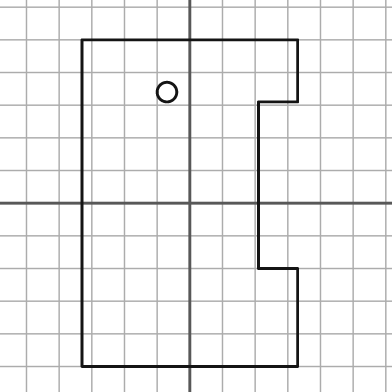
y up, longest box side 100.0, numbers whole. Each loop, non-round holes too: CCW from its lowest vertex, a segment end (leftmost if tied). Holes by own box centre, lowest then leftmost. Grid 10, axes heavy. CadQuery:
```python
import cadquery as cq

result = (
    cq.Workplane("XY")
    .moveTo(-33.0, -50.0)
    .lineTo(33.0, -50.0)
    .lineTo(33.0, -20.0)
    .lineTo(21.0, -20.0)
    .lineTo(21.0, 31.0)
    .lineTo(33.0, 31.0)
    .lineTo(33.0, 50.0)
    .lineTo(-33.0, 50.0)
    .close()
    .moveTo(-7.0, 34.0)
    .circle(3.0)
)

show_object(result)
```